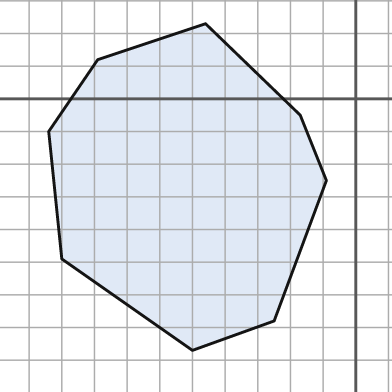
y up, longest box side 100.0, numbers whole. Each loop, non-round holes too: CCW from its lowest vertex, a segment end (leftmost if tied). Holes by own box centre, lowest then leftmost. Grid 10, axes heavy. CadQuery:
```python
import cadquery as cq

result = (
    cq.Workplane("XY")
    .moveTo(-50.0, -77.0)
    .lineTo(-25.0, -68.0)
    .lineTo(-9.0, -25.0)
    .lineTo(-17.0, -5.0)
    .lineTo(-46.0, 23.0)
    .lineTo(-79.0, 12.0)
    .lineTo(-94.0, -10.0)
    .lineTo(-90.0, -49.0)
    .close()
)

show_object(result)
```